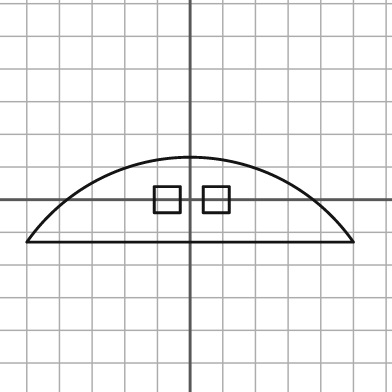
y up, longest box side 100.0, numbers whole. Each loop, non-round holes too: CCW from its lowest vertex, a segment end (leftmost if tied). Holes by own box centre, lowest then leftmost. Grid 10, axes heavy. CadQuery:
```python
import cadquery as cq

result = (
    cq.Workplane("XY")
    .moveTo(-50.0, -13.0)
    .lineTo(50.0, -13.0)
    .threePointArc((0.0, 13.0), (-50.0, -13.0))
    .close()
    .moveTo(-11.0, -4.0)
    .lineTo(-3.0, -4.0)
    .lineTo(-3.0, 4.0)
    .lineTo(-11.0, 4.0)
    .close()
    .moveTo(4.0, -4.0)
    .lineTo(12.0, -4.0)
    .lineTo(12.0, 4.0)
    .lineTo(4.0, 4.0)
    .close()
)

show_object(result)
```